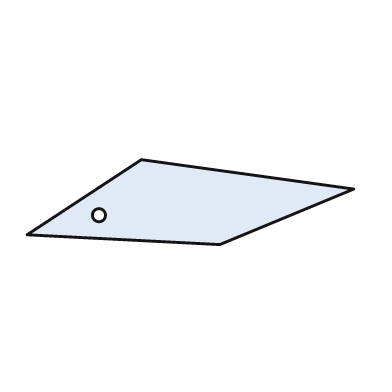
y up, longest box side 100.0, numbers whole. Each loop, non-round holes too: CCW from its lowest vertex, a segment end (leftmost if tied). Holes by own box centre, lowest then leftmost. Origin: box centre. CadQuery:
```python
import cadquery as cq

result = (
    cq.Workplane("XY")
    .moveTo(9.0, -13.0)
    .lineTo(50.0, 4.0)
    .lineTo(-15.0, 13.0)
    .lineTo(-50.0, -10.0)
    .close()
    .moveTo(-28.0, -4.0)
    .circle(2.0)
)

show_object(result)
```